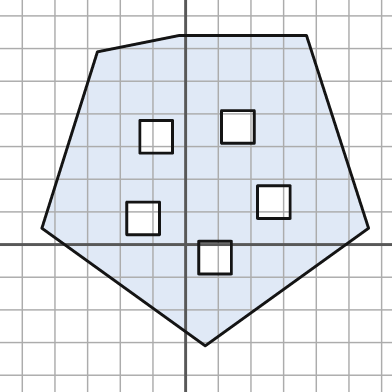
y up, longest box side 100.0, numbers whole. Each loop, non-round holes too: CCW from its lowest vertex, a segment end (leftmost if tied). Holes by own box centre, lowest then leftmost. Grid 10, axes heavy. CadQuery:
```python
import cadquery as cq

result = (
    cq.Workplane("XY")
    .moveTo(6.0, -31.0)
    .lineTo(56.0, 5.0)
    .lineTo(37.0, 64.0)
    .lineTo(-2.0, 64.0)
    .lineTo(-27.0, 59.0)
    .lineTo(-44.0, 5.0)
    .close()
    .moveTo(4.0, -9.0)
    .lineTo(14.0, -9.0)
    .lineTo(14.0, 1.0)
    .lineTo(4.0, 1.0)
    .close()
    .moveTo(-18.0, 3.0)
    .lineTo(-8.0, 3.0)
    .lineTo(-8.0, 13.0)
    .lineTo(-18.0, 13.0)
    .close()
    .moveTo(22.0, 8.0)
    .lineTo(32.0, 8.0)
    .lineTo(32.0, 18.0)
    .lineTo(22.0, 18.0)
    .close()
    .moveTo(-14.0, 28.0)
    .lineTo(-4.0, 28.0)
    .lineTo(-4.0, 38.0)
    .lineTo(-14.0, 38.0)
    .close()
    .moveTo(11.0, 31.0)
    .lineTo(21.0, 31.0)
    .lineTo(21.0, 41.0)
    .lineTo(11.0, 41.0)
    .close()
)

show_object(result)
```